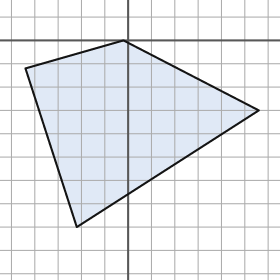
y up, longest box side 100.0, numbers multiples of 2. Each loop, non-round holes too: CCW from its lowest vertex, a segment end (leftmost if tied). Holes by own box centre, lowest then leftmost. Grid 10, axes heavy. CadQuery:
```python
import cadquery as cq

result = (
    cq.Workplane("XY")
    .moveTo(-22.0, -80.0)
    .lineTo(56.0, -30.0)
    .lineTo(-2.0, 0.0)
    .lineTo(-44.0, -12.0)
    .close()
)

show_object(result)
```